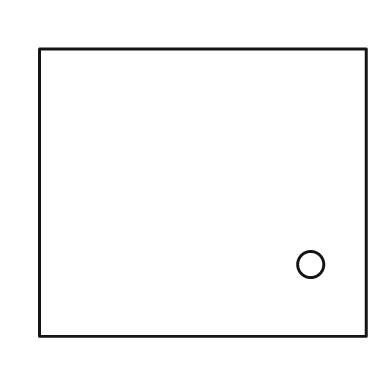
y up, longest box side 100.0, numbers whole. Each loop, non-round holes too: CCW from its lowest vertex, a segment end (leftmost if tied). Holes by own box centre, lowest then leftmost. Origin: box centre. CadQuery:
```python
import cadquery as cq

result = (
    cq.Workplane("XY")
    .moveTo(-50.0, -44.0)
    .lineTo(50.0, -44.0)
    .lineTo(50.0, 44.0)
    .lineTo(-50.0, 44.0)
    .close()
    .moveTo(33.0, -22.0)
    .circle(4.0)
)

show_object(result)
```